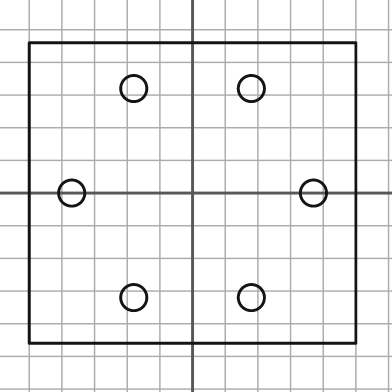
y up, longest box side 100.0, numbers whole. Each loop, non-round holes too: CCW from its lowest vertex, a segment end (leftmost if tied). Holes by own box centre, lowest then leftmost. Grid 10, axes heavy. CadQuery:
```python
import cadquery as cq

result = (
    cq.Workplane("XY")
    .moveTo(-50.0, -46.0)
    .lineTo(50.0, -46.0)
    .lineTo(50.0, 46.0)
    .lineTo(-50.0, 46.0)
    .close()
    .moveTo(-18.0, -32.0)
    .circle(4.0)
    .moveTo(18.0, -32.0)
    .circle(4.0)
    .moveTo(-37.0, 0.0)
    .circle(4.0)
    .moveTo(37.0, 0.0)
    .circle(4.0)
    .moveTo(-18.0, 32.0)
    .circle(4.0)
    .moveTo(18.0, 32.0)
    .circle(4.0)
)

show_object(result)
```